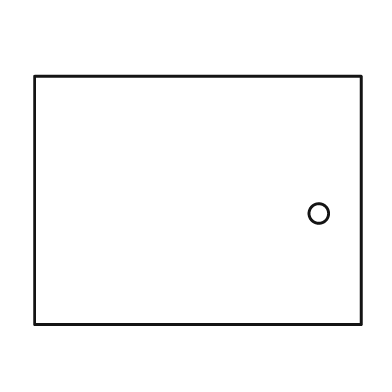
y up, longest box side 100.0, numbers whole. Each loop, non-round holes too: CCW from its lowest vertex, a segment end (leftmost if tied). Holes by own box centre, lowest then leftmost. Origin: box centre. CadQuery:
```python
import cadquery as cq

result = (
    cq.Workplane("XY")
    .moveTo(-50.0, -38.0)
    .lineTo(50.0, -38.0)
    .lineTo(50.0, 38.0)
    .lineTo(-50.0, 38.0)
    .close()
    .moveTo(37.0, -4.0)
    .circle(3.0)
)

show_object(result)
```